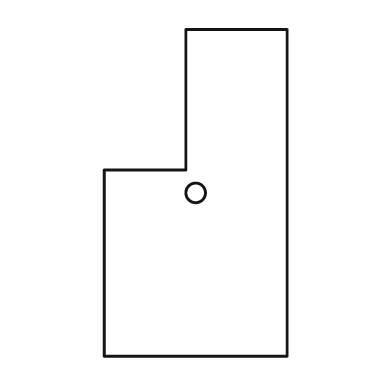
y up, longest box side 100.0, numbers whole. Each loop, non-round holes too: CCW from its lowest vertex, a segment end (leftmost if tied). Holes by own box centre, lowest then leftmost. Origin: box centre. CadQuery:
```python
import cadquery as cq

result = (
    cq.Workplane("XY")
    .moveTo(-28.0, -50.0)
    .lineTo(28.0, -50.0)
    .lineTo(28.0, 50.0)
    .lineTo(-3.0, 50.0)
    .lineTo(-3.0, 7.0)
    .lineTo(-28.0, 7.0)
    .close()
    .moveTo(0.0, 0.0)
    .circle(3.0)
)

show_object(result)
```